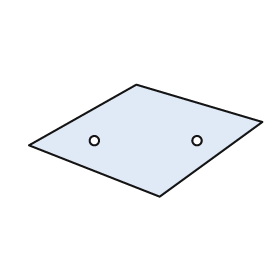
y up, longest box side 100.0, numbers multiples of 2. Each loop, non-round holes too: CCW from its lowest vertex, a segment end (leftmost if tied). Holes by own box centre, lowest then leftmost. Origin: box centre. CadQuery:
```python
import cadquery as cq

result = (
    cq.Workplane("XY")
    .moveTo(6.0, -24.0)
    .lineTo(50.0, 8.0)
    .lineTo(-4.0, 24.0)
    .lineTo(-50.0, -2.0)
    .close()
    .moveTo(-22.0, 0.0)
    .circle(2.0)
    .moveTo(22.0, 0.0)
    .circle(2.0)
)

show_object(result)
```